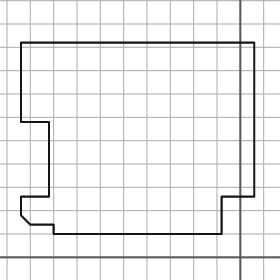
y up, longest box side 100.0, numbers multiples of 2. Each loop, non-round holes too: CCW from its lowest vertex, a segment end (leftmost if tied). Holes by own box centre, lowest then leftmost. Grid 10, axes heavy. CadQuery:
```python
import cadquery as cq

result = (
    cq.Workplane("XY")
    .moveTo(-80.0, 10.0)
    .lineTo(-8.0, 10.0)
    .lineTo(-8.0, 26.0)
    .lineTo(6.0, 26.0)
    .lineTo(6.0, 92.0)
    .lineTo(-94.0, 92.0)
    .lineTo(-94.0, 58.0)
    .lineTo(-82.0, 58.0)
    .lineTo(-82.0, 26.0)
    .lineTo(-94.0, 26.0)
    .lineTo(-94.0, 18.0)
    .lineTo(-90.0, 14.0)
    .lineTo(-80.0, 14.0)
    .close()
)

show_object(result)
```